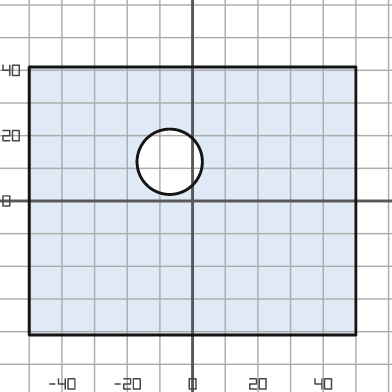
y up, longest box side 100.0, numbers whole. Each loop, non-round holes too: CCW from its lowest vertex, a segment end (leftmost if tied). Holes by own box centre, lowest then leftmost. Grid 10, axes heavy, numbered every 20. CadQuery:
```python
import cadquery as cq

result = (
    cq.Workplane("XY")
    .moveTo(-50.0, -41.0)
    .lineTo(50.0, -41.0)
    .lineTo(50.0, 41.0)
    .lineTo(-50.0, 41.0)
    .close()
    .moveTo(-7.0, 12.0)
    .circle(10.0)
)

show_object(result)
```